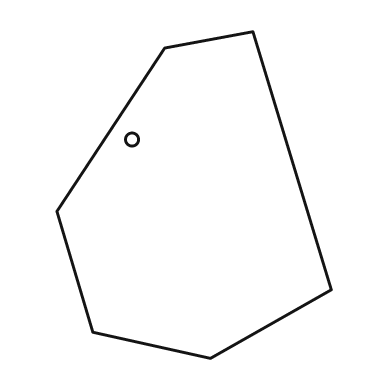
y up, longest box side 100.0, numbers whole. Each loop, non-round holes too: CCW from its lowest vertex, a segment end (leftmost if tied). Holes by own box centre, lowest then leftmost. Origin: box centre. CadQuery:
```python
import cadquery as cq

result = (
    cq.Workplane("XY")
    .moveTo(5.0, -50.0)
    .lineTo(42.0, -29.0)
    .lineTo(18.0, 50.0)
    .lineTo(-9.0, 45.0)
    .lineTo(-42.0, -5.0)
    .lineTo(-31.0, -42.0)
    .close()
    .moveTo(-19.0, 17.0)
    .circle(2.0)
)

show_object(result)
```